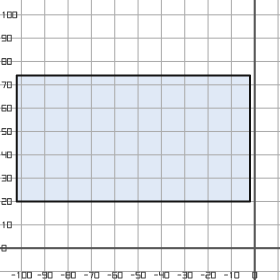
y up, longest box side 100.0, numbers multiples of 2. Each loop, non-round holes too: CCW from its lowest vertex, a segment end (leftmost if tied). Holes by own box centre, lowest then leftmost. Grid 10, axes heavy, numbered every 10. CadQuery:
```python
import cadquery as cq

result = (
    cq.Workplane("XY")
    .moveTo(-102.0, 20.0)
    .lineTo(-2.0, 20.0)
    .lineTo(-2.0, 74.0)
    .lineTo(-102.0, 74.0)
    .close()
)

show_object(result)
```